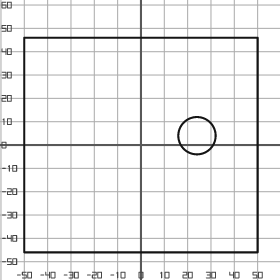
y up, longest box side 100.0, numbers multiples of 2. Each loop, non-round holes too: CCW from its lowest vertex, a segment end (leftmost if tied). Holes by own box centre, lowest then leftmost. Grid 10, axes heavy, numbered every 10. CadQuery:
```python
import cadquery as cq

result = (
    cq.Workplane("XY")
    .moveTo(-50.0, -46.0)
    .lineTo(50.0, -46.0)
    .lineTo(50.0, 46.0)
    .lineTo(-50.0, 46.0)
    .close()
    .moveTo(24.0, 4.0)
    .circle(8.0)
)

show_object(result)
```